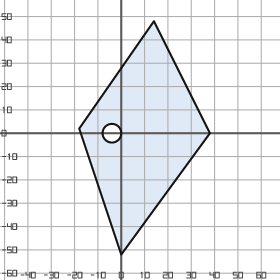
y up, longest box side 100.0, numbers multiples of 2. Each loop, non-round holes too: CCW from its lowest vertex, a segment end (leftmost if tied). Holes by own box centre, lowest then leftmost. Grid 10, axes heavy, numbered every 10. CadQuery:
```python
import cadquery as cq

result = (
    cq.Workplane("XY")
    .moveTo(0.0, -52.0)
    .lineTo(38.0, 0.0)
    .lineTo(14.0, 48.0)
    .lineTo(-18.0, 2.0)
    .close()
    .moveTo(-4.0, 0.0)
    .circle(4.0)
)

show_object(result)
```